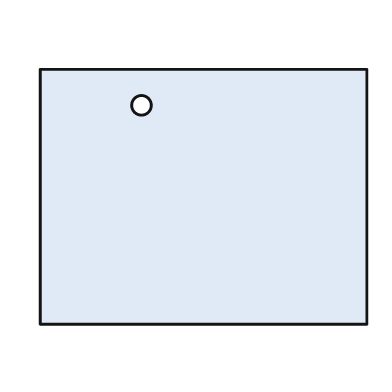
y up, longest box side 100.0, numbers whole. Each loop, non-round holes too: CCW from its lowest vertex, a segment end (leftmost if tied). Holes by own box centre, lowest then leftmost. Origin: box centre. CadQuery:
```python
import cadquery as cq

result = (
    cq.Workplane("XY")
    .moveTo(-50.0, -39.0)
    .lineTo(50.0, -39.0)
    .lineTo(50.0, 39.0)
    .lineTo(-50.0, 39.0)
    .close()
    .moveTo(-19.0, 28.0)
    .circle(3.0)
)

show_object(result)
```